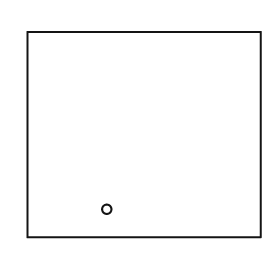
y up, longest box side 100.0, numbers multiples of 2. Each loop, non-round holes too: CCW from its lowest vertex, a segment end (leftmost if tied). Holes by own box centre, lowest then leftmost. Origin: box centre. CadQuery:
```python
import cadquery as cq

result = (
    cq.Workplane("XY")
    .moveTo(-50.0, -44.0)
    .lineTo(50.0, -44.0)
    .lineTo(50.0, 44.0)
    .lineTo(-50.0, 44.0)
    .close()
    .moveTo(-16.0, -32.0)
    .circle(2.0)
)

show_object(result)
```